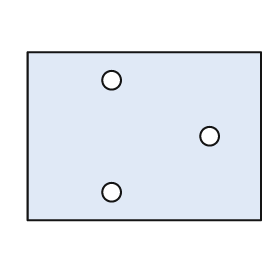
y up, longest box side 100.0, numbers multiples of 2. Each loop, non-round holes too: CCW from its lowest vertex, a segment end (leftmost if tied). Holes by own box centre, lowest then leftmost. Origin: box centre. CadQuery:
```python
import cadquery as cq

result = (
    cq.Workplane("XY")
    .moveTo(-50.0, -36.0)
    .lineTo(50.0, -36.0)
    .lineTo(50.0, 36.0)
    .lineTo(-50.0, 36.0)
    .close()
    .moveTo(-14.0, -24.0)
    .circle(4.0)
    .moveTo(28.0, 0.0)
    .circle(4.0)
    .moveTo(-14.0, 24.0)
    .circle(4.0)
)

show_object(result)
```